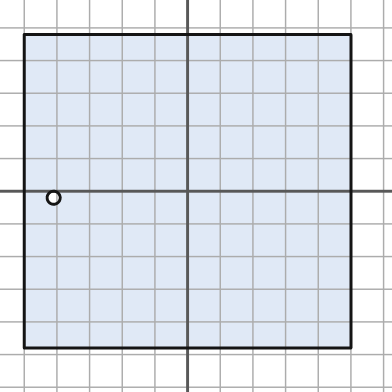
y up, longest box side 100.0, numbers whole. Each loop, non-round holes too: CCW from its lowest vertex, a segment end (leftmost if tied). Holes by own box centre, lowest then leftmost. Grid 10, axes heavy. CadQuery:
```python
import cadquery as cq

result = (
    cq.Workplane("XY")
    .moveTo(-50.0, -48.0)
    .lineTo(50.0, -48.0)
    .lineTo(50.0, 48.0)
    .lineTo(-50.0, 48.0)
    .close()
    .moveTo(-41.0, -2.0)
    .circle(2.0)
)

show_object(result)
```